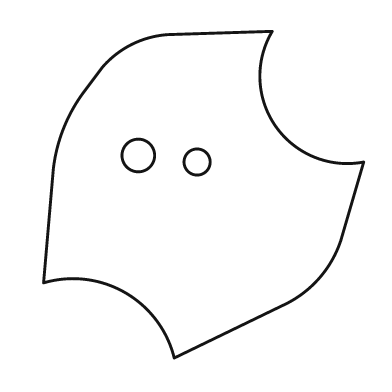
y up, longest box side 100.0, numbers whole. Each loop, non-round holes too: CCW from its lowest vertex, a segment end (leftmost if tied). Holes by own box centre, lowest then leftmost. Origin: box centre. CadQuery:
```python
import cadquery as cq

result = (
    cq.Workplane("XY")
    .moveTo(-9.0, -50.0)
    .lineTo(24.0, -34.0)
    .threePointArc((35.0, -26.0), (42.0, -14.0))
    .lineTo(49.0, 10.0)
    .threePointArc((22.0, 21.0), (21.0, 50.0))
    .lineTo(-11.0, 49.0)
    .threePointArc((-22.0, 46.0), (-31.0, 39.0))
    .lineTo(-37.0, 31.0)
    .threePointArc((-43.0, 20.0), (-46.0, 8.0))
    .lineTo(-49.0, -27.0)
    .threePointArc((-24.0, -30.0), (-9.0, -50.0))
    .close()
    .moveTo(-2.0, 10.0)
    .circle(4.0)
    .moveTo(-20.0, 12.0)
    .circle(5.0)
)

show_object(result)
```